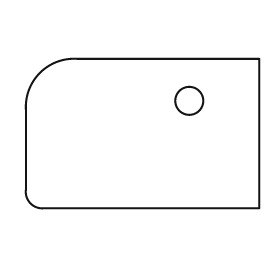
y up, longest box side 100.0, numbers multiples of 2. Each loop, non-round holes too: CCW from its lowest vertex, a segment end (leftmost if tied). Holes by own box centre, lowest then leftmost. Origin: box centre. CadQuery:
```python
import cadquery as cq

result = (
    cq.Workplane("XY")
    .moveTo(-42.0, -32.0)
    .lineTo(50.0, -32.0)
    .lineTo(50.0, 32.0)
    .lineTo(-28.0, 32.0)
    .threePointArc((-44.0, 26.0), (-50.0, 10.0))
    .lineTo(-50.0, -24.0)
    .threePointArc((-48.0, -30.0), (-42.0, -32.0))
    .close()
    .moveTo(20.0, 14.0)
    .circle(6.0)
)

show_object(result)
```